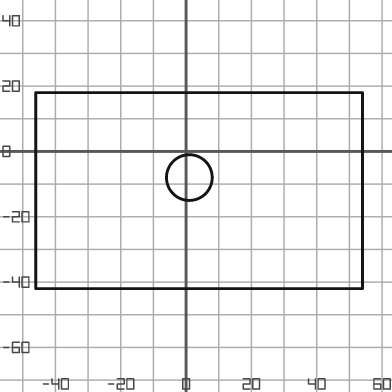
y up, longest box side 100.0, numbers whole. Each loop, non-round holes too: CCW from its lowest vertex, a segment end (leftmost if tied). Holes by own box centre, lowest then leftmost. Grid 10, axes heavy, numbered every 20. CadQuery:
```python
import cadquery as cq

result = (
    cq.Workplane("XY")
    .moveTo(-46.0, -42.0)
    .lineTo(54.0, -42.0)
    .lineTo(54.0, 18.0)
    .lineTo(-46.0, 18.0)
    .close()
    .moveTo(1.0, -8.0)
    .circle(7.0)
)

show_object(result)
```